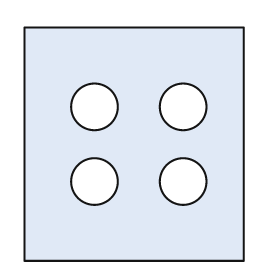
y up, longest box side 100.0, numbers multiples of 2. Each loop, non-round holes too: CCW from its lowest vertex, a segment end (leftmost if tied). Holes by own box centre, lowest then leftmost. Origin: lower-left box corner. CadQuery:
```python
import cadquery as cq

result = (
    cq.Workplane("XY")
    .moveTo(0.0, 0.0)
    .lineTo(94.0, 0.0)
    .lineTo(94.0, 100.0)
    .lineTo(0.0, 100.0)
    .close()
    .moveTo(30.0, 34.0)
    .circle(10.0)
    .moveTo(68.0, 34.0)
    .circle(10.0)
    .moveTo(30.0, 66.0)
    .circle(10.0)
    .moveTo(68.0, 66.0)
    .circle(10.0)
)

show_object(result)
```